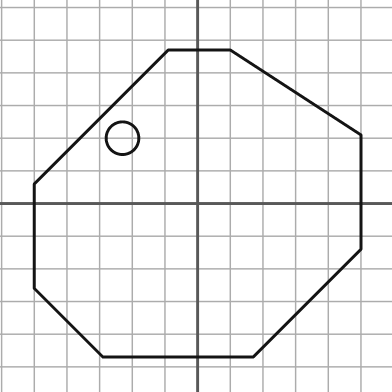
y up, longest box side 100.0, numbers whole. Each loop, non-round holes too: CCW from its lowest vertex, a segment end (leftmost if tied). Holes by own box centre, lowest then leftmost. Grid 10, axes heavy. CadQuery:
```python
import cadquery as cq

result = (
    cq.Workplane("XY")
    .moveTo(-29.0, -47.0)
    .lineTo(17.0, -47.0)
    .lineTo(50.0, -14.0)
    .lineTo(50.0, 21.0)
    .lineTo(10.0, 47.0)
    .lineTo(-9.0, 47.0)
    .lineTo(-50.0, 6.0)
    .lineTo(-50.0, -26.0)
    .close()
    .moveTo(-23.0, 20.0)
    .circle(5.0)
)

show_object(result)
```